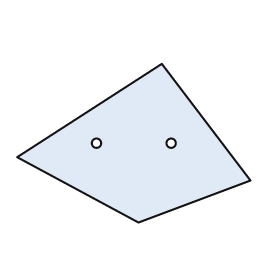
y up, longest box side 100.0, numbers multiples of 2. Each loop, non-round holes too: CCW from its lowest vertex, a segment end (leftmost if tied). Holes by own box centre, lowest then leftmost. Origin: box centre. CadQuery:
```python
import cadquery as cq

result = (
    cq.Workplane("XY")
    .moveTo(2.0, -34.0)
    .lineTo(50.0, -16.0)
    .lineTo(12.0, 34.0)
    .lineTo(-50.0, -6.0)
    .close()
    .moveTo(-16.0, 0.0)
    .circle(2.0)
    .moveTo(16.0, 0.0)
    .circle(2.0)
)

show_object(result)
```